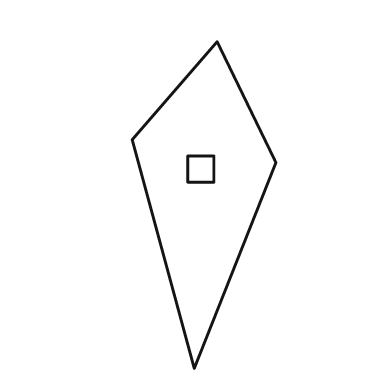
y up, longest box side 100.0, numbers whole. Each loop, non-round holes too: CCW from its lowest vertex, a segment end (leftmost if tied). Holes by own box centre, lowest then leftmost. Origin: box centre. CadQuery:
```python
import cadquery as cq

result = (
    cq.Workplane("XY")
    .moveTo(-3.0, -50.0)
    .lineTo(22.0, 13.0)
    .lineTo(4.0, 50.0)
    .lineTo(-22.0, 20.0)
    .close()
    .moveTo(-5.0, 7.0)
    .lineTo(3.0, 7.0)
    .lineTo(3.0, 15.0)
    .lineTo(-5.0, 15.0)
    .close()
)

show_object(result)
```